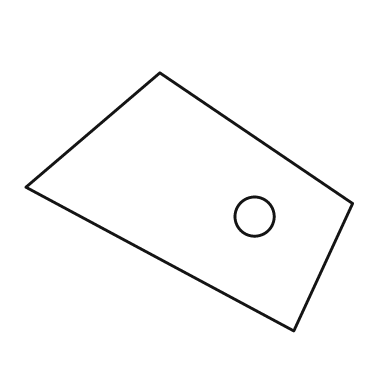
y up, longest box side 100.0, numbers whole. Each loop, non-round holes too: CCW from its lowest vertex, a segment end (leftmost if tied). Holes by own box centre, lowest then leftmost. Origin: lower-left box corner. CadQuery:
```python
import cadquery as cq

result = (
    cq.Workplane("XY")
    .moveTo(82.0, 0.0)
    .lineTo(100.0, 39.0)
    .lineTo(41.0, 79.0)
    .lineTo(0.0, 44.0)
    .close()
    .moveTo(70.0, 35.0)
    .circle(6.0)
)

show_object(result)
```